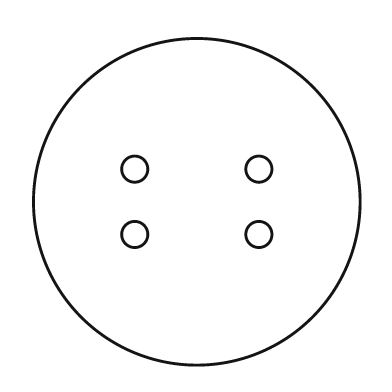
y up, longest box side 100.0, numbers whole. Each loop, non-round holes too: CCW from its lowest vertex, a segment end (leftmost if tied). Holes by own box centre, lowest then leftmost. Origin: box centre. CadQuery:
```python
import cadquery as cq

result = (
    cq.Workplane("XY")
    .moveTo(0.0, 0.0)
    .circle(50.0)
    .moveTo(-19.0, -10.0)
    .circle(4.0)
    .moveTo(19.0, -10.0)
    .circle(4.0)
    .moveTo(-19.0, 10.0)
    .circle(4.0)
    .moveTo(19.0, 10.0)
    .circle(4.0)
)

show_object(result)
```